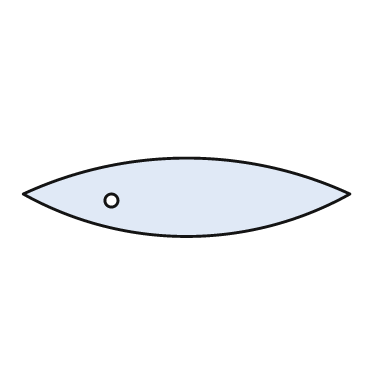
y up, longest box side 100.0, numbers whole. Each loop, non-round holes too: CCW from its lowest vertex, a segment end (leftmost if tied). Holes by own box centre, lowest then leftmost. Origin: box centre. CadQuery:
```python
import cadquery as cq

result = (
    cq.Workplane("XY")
    .moveTo(-50.0, 1.0)
    .threePointArc((0.0, -12.0), (50.0, 1.0))
    .threePointArc((0.0, 12.0), (-50.0, 1.0))
    .close()
    .moveTo(-23.0, -1.0)
    .circle(2.0)
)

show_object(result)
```